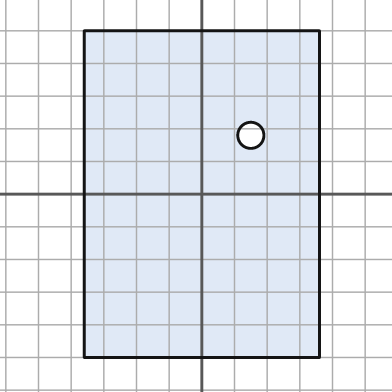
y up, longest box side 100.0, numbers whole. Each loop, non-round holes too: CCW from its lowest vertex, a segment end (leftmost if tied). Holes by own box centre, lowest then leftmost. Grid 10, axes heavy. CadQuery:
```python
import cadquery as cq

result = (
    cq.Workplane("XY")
    .moveTo(-36.0, -50.0)
    .lineTo(36.0, -50.0)
    .lineTo(36.0, 50.0)
    .lineTo(-36.0, 50.0)
    .close()
    .moveTo(15.0, 18.0)
    .circle(4.0)
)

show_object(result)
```